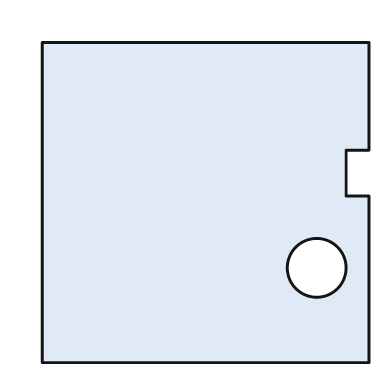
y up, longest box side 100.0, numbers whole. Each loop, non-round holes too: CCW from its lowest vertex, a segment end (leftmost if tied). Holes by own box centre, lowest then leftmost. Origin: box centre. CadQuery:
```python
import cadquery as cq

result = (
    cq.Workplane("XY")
    .moveTo(-50.0, -49.0)
    .lineTo(50.0, -49.0)
    .lineTo(50.0, 2.0)
    .lineTo(43.0, 2.0)
    .lineTo(43.0, 16.0)
    .lineTo(50.0, 16.0)
    .lineTo(50.0, 49.0)
    .lineTo(-50.0, 49.0)
    .close()
    .moveTo(34.0, -20.0)
    .circle(9.0)
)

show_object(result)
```